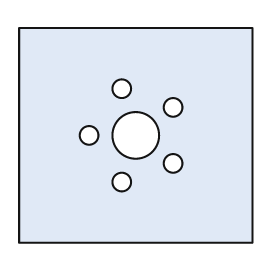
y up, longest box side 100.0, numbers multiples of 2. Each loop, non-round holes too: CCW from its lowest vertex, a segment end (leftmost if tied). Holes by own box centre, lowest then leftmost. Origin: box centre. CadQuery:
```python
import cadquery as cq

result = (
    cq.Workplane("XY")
    .moveTo(-50.0, -46.0)
    .lineTo(50.0, -46.0)
    .lineTo(50.0, 46.0)
    .lineTo(-50.0, 46.0)
    .close()
    .moveTo(-6.0, -20.0)
    .circle(4.0)
    .moveTo(16.0, -12.0)
    .circle(4.0)
    .moveTo(-20.0, 0.0)
    .circle(4.0)
    .moveTo(0.0, 0.0)
    .circle(10.0)
    .moveTo(16.0, 12.0)
    .circle(4.0)
    .moveTo(-6.0, 20.0)
    .circle(4.0)
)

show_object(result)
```